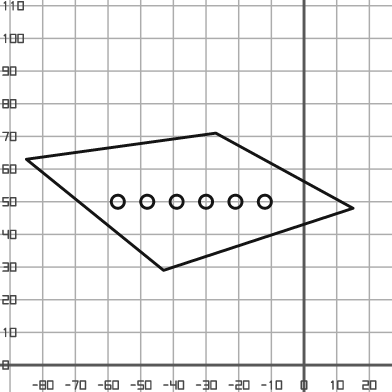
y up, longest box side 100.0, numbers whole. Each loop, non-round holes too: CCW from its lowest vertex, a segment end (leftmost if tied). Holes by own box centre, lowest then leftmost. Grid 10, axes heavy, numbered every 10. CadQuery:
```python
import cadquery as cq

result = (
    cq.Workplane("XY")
    .moveTo(-43.0, 29.0)
    .lineTo(15.0, 48.0)
    .lineTo(-27.0, 71.0)
    .lineTo(-85.0, 63.0)
    .close()
    .moveTo(-57.0, 50.0)
    .circle(2.0)
    .moveTo(-48.0, 50.0)
    .circle(2.0)
    .moveTo(-39.0, 50.0)
    .circle(2.0)
    .moveTo(-30.0, 50.0)
    .circle(2.0)
    .moveTo(-21.0, 50.0)
    .circle(2.0)
    .moveTo(-12.0, 50.0)
    .circle(2.0)
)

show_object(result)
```